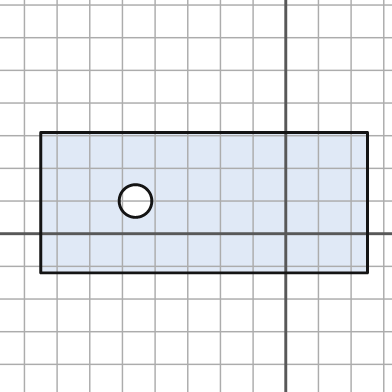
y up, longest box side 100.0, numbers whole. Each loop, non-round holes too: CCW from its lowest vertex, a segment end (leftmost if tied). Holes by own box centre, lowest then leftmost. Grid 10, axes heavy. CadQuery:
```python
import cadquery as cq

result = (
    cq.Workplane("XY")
    .moveTo(-75.0, -12.0)
    .lineTo(25.0, -12.0)
    .lineTo(25.0, 31.0)
    .lineTo(-75.0, 31.0)
    .close()
    .moveTo(-46.0, 10.0)
    .circle(5.0)
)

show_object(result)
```